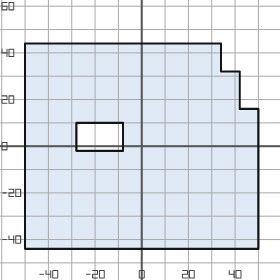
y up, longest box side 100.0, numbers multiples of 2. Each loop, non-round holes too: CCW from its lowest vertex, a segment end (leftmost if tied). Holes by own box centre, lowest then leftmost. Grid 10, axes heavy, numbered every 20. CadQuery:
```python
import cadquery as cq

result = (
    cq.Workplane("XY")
    .moveTo(-50.0, -44.0)
    .lineTo(50.0, -44.0)
    .lineTo(50.0, 16.0)
    .lineTo(42.0, 16.0)
    .lineTo(42.0, 32.0)
    .lineTo(34.0, 32.0)
    .lineTo(34.0, 44.0)
    .lineTo(-50.0, 44.0)
    .close()
    .moveTo(-28.0, -2.0)
    .lineTo(-8.0, -2.0)
    .lineTo(-8.0, 10.0)
    .lineTo(-28.0, 10.0)
    .close()
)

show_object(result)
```